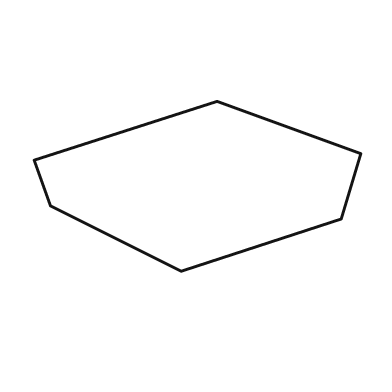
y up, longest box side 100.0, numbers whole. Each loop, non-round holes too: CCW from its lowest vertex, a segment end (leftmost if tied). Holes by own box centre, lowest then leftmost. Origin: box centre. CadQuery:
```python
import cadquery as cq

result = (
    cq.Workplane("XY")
    .moveTo(-5.0, -26.0)
    .lineTo(44.0, -10.0)
    .lineTo(50.0, 10.0)
    .lineTo(6.0, 26.0)
    .lineTo(-50.0, 8.0)
    .lineTo(-45.0, -6.0)
    .close()
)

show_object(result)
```